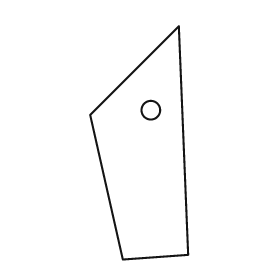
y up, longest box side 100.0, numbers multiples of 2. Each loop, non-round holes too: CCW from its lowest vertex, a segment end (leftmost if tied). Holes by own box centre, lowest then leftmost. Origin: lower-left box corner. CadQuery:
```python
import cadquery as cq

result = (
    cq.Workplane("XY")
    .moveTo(14.0, 0.0)
    .lineTo(42.0, 2.0)
    .lineTo(38.0, 100.0)
    .lineTo(0.0, 62.0)
    .close()
    .moveTo(26.0, 64.0)
    .circle(4.0)
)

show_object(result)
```